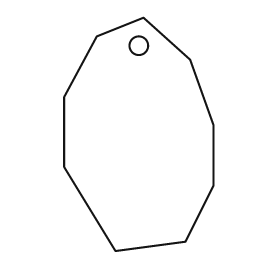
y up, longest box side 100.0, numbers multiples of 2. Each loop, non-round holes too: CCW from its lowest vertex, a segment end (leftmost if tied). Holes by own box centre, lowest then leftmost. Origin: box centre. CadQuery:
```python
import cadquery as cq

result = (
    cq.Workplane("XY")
    .moveTo(-10.0, -50.0)
    .lineTo(20.0, -46.0)
    .lineTo(32.0, -22.0)
    .lineTo(32.0, 4.0)
    .lineTo(22.0, 32.0)
    .lineTo(2.0, 50.0)
    .lineTo(-18.0, 42.0)
    .lineTo(-32.0, 16.0)
    .lineTo(-32.0, -14.0)
    .close()
    .moveTo(0.0, 38.0)
    .circle(4.0)
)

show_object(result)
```